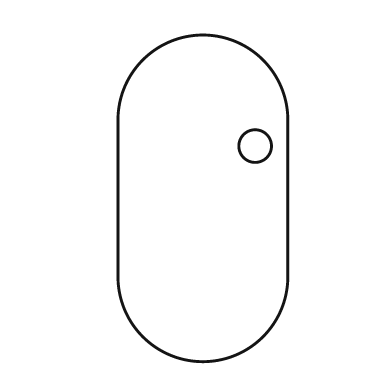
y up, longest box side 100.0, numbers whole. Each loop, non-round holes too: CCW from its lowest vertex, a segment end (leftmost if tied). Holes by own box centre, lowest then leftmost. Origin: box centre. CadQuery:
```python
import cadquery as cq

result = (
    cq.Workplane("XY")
    .moveTo(-26.0, -24.0)
    .threePointArc((0.0, -50.0), (26.0, -24.0))
    .lineTo(26.0, 24.0)
    .threePointArc((0.0, 50.0), (-26.0, 24.0))
    .close()
    .moveTo(16.0, 16.0)
    .circle(5.0)
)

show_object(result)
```